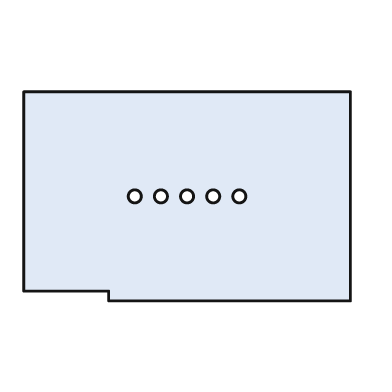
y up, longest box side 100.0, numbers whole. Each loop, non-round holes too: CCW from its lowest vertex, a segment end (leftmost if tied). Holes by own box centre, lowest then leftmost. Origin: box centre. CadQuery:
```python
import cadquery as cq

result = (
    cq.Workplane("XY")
    .moveTo(-24.0, -32.0)
    .lineTo(50.0, -32.0)
    .lineTo(50.0, 32.0)
    .lineTo(-50.0, 32.0)
    .lineTo(-50.0, -29.0)
    .lineTo(-24.0, -29.0)
    .close()
    .moveTo(-16.0, 0.0)
    .circle(2.0)
    .moveTo(-8.0, 0.0)
    .circle(2.0)
    .moveTo(0.0, 0.0)
    .circle(2.0)
    .moveTo(8.0, 0.0)
    .circle(2.0)
    .moveTo(16.0, 0.0)
    .circle(2.0)
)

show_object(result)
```